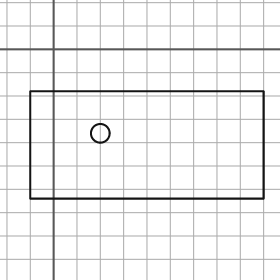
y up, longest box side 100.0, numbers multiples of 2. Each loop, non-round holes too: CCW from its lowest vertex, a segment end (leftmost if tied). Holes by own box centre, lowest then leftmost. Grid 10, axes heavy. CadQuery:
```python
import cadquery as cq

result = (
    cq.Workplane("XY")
    .moveTo(-10.0, -64.0)
    .lineTo(90.0, -64.0)
    .lineTo(90.0, -18.0)
    .lineTo(-10.0, -18.0)
    .close()
    .moveTo(20.0, -36.0)
    .circle(4.0)
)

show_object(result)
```